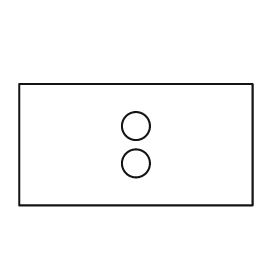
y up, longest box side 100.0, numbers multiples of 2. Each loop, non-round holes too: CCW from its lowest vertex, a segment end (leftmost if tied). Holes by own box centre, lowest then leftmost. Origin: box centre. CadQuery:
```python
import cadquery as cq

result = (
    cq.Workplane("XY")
    .moveTo(-50.0, -26.0)
    .lineTo(50.0, -26.0)
    .lineTo(50.0, 26.0)
    .lineTo(-50.0, 26.0)
    .close()
    .moveTo(0.0, -8.0)
    .circle(6.0)
    .moveTo(0.0, 8.0)
    .circle(6.0)
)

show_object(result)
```